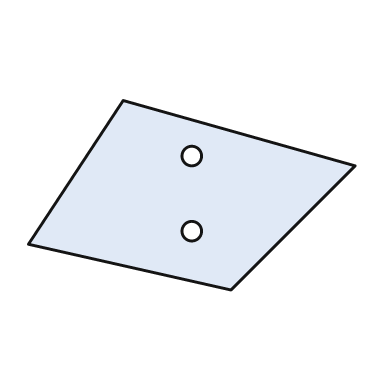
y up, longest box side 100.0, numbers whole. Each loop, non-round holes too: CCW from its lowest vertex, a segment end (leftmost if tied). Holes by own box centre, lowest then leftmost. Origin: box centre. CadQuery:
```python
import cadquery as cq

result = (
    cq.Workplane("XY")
    .moveTo(12.0, -29.0)
    .lineTo(50.0, 9.0)
    .lineTo(-21.0, 29.0)
    .lineTo(-50.0, -15.0)
    .close()
    .moveTo(0.0, -11.0)
    .circle(3.0)
    .moveTo(0.0, 12.0)
    .circle(3.0)
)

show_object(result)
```